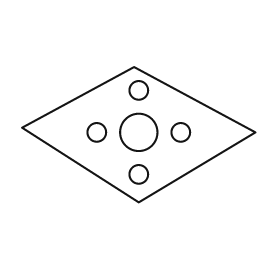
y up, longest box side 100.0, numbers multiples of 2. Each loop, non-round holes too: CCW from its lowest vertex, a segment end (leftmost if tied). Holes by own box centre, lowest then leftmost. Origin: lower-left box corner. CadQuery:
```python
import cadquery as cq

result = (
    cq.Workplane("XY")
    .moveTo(50.0, 0.0)
    .lineTo(100.0, 30.0)
    .lineTo(48.0, 58.0)
    .lineTo(0.0, 32.0)
    .close()
    .moveTo(50.0, 12.0)
    .circle(4.0)
    .moveTo(32.0, 30.0)
    .circle(4.0)
    .moveTo(50.0, 30.0)
    .circle(8.0)
    .moveTo(68.0, 30.0)
    .circle(4.0)
    .moveTo(50.0, 48.0)
    .circle(4.0)
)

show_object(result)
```